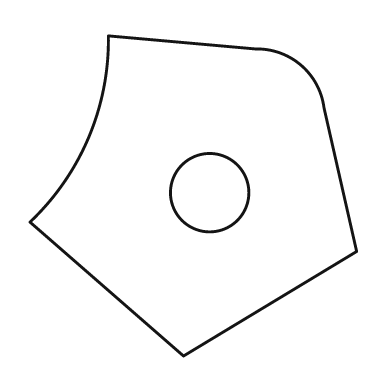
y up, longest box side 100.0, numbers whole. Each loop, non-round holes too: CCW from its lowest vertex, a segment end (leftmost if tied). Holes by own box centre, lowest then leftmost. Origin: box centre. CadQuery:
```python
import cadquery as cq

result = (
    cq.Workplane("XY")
    .moveTo(-3.0, -49.0)
    .lineTo(50.0, -17.0)
    .lineTo(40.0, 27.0)
    .threePointArc((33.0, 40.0), (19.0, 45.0))
    .lineTo(-26.0, 49.0)
    .threePointArc((-32.0, 18.0), (-50.0, -8.0))
    .close()
    .moveTo(5.0, 1.0)
    .circle(12.0)
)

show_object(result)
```